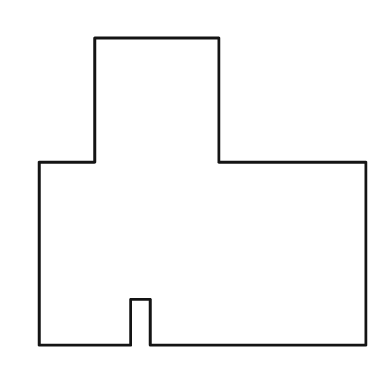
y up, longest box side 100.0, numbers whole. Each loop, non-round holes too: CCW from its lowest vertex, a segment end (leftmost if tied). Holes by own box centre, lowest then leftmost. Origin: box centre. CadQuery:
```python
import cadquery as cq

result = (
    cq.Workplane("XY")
    .moveTo(-50.0, -47.0)
    .lineTo(-22.0, -47.0)
    .lineTo(-22.0, -33.0)
    .lineTo(-16.0, -33.0)
    .lineTo(-16.0, -47.0)
    .lineTo(50.0, -47.0)
    .lineTo(50.0, 9.0)
    .lineTo(5.0, 9.0)
    .lineTo(5.0, 47.0)
    .lineTo(-33.0, 47.0)
    .lineTo(-33.0, 9.0)
    .lineTo(-50.0, 9.0)
    .close()
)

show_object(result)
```